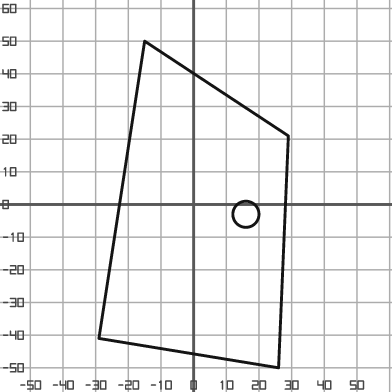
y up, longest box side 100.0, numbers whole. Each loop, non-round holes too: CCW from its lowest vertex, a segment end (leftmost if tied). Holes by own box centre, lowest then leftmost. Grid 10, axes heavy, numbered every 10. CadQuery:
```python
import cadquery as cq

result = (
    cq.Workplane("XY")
    .moveTo(26.0, -50.0)
    .lineTo(29.0, 21.0)
    .lineTo(-15.0, 50.0)
    .lineTo(-29.0, -41.0)
    .close()
    .moveTo(16.0, -3.0)
    .circle(4.0)
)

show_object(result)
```